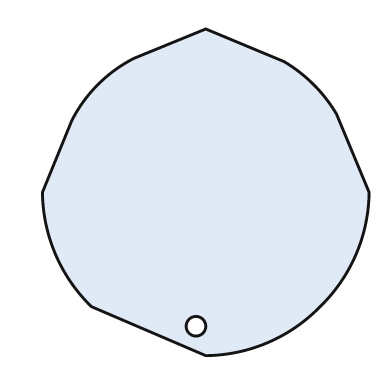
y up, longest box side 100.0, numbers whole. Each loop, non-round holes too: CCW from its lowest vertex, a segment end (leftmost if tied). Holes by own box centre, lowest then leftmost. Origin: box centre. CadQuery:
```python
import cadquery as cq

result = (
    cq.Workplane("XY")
    .moveTo(0.0, -50.0)
    .threePointArc((19.0, -46.0), (35.0, -35.0))
    .threePointArc((46.0, -19.0), (50.0, 0.0))
    .lineTo(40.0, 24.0)
    .threePointArc((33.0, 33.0), (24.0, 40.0))
    .lineTo(0.0, 50.0)
    .lineTo(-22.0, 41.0)
    .threePointArc((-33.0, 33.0), (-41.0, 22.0))
    .lineTo(-50.0, 0.0)
    .threePointArc((-46.0, -19.0), (-35.0, -35.0))
    .close()
    .moveTo(-3.0, -41.0)
    .circle(3.0)
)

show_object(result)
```